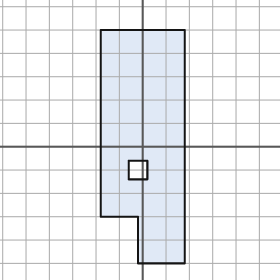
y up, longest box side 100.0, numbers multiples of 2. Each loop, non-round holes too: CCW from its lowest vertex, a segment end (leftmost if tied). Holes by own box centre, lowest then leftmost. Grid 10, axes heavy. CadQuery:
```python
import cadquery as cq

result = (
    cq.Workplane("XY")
    .moveTo(-2.0, -50.0)
    .lineTo(18.0, -50.0)
    .lineTo(18.0, 50.0)
    .lineTo(-18.0, 50.0)
    .lineTo(-18.0, -30.0)
    .lineTo(-2.0, -30.0)
    .close()
    .moveTo(-6.0, -14.0)
    .lineTo(2.0, -14.0)
    .lineTo(2.0, -6.0)
    .lineTo(-6.0, -6.0)
    .close()
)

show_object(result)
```